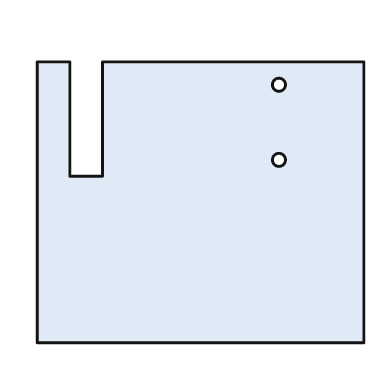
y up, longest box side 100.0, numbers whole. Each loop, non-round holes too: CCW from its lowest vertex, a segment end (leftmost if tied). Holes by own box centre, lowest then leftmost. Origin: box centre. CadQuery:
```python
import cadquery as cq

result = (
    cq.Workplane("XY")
    .moveTo(-50.0, -43.0)
    .lineTo(50.0, -43.0)
    .lineTo(50.0, 43.0)
    .lineTo(-30.0, 43.0)
    .lineTo(-30.0, 8.0)
    .lineTo(-40.0, 8.0)
    .lineTo(-40.0, 43.0)
    .lineTo(-50.0, 43.0)
    .close()
    .moveTo(24.0, 13.0)
    .circle(2.0)
    .moveTo(24.0, 36.0)
    .circle(2.0)
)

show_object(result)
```